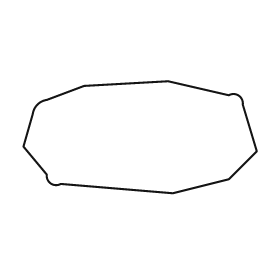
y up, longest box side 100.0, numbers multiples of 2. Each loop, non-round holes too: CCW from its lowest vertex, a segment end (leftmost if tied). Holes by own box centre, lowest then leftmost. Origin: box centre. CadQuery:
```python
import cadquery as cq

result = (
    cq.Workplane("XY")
    .moveTo(14.0, -24.0)
    .lineTo(38.0, -18.0)
    .lineTo(50.0, -6.0)
    .lineTo(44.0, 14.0)
    .threePointArc((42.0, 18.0), (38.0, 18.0))
    .lineTo(12.0, 24.0)
    .lineTo(-24.0, 22.0)
    .lineTo(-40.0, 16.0)
    .threePointArc((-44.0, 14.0), (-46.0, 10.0))
    .lineTo(-50.0, -4.0)
    .lineTo(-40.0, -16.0)
    .threePointArc((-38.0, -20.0), (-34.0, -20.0))
    .close()
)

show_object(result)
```